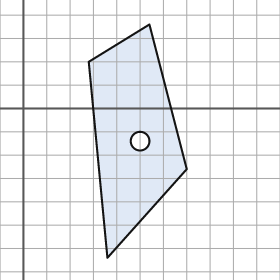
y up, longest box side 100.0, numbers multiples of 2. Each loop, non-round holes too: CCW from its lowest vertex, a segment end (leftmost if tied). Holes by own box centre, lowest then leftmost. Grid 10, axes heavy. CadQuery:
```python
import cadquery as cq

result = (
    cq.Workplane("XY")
    .moveTo(36.0, -64.0)
    .lineTo(70.0, -26.0)
    .lineTo(54.0, 36.0)
    .lineTo(28.0, 20.0)
    .close()
    .moveTo(50.0, -14.0)
    .circle(4.0)
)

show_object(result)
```